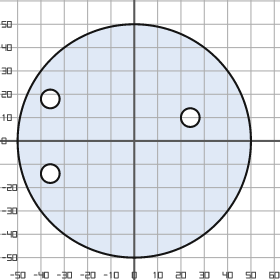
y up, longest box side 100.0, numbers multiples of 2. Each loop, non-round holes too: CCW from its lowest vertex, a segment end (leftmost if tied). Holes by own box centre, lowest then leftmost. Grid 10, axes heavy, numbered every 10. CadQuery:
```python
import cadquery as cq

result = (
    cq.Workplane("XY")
    .moveTo(0.0, 0.0)
    .circle(50.0)
    .moveTo(-36.0, -14.0)
    .circle(4.0)
    .moveTo(24.0, 10.0)
    .circle(4.0)
    .moveTo(-36.0, 18.0)
    .circle(4.0)
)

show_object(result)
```